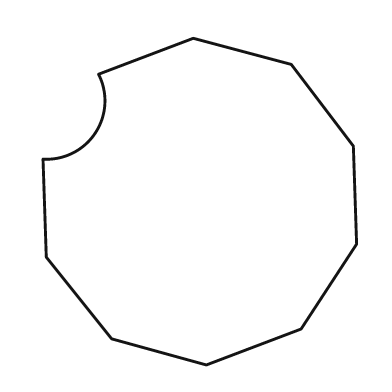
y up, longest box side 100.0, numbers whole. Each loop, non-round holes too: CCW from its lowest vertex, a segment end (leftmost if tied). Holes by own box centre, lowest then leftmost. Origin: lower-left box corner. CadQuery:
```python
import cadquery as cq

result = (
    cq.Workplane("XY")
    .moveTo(50.0, 0.0)
    .lineTo(79.0, 11.0)
    .lineTo(96.0, 37.0)
    .lineTo(95.0, 67.0)
    .lineTo(76.0, 92.0)
    .lineTo(46.0, 100.0)
    .lineTo(17.0, 89.0)
    .threePointArc((16.0, 71.0), (0.0, 63.0))
    .lineTo(1.0, 33.0)
    .lineTo(21.0, 8.0)
    .close()
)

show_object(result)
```